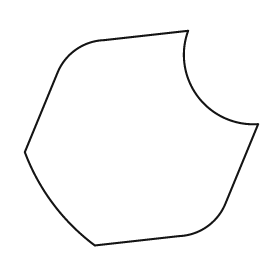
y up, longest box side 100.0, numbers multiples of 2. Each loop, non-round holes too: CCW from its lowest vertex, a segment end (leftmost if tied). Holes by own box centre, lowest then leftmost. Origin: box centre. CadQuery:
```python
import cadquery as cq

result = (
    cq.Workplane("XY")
    .moveTo(-20.0, -46.0)
    .lineTo(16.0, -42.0)
    .threePointArc((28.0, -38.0), (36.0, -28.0))
    .lineTo(50.0, 6.0)
    .threePointArc((24.0, 18.0), (20.0, 46.0))
    .lineTo(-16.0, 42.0)
    .threePointArc((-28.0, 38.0), (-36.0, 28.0))
    .lineTo(-50.0, -6.0)
    .threePointArc((-38.0, -28.0), (-20.0, -46.0))
    .close()
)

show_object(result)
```